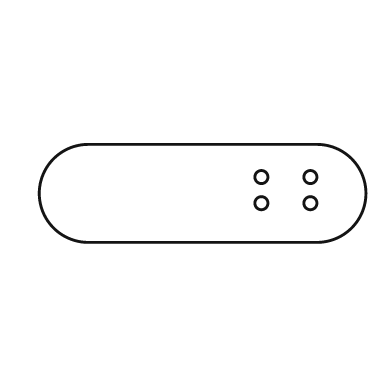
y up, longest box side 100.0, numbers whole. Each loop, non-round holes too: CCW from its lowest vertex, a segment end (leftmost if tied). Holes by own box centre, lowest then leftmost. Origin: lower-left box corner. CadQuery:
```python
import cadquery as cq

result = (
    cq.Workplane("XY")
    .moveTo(15.0, 0.0)
    .lineTo(85.0, 0.0)
    .threePointArc((100.0, 15.0), (85.0, 30.0))
    .lineTo(15.0, 30.0)
    .threePointArc((0.0, 15.0), (15.0, 0.0))
    .close()
    .moveTo(68.0, 12.0)
    .circle(2.0)
    .moveTo(83.0, 12.0)
    .circle(2.0)
    .moveTo(68.0, 20.0)
    .circle(2.0)
    .moveTo(83.0, 20.0)
    .circle(2.0)
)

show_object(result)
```